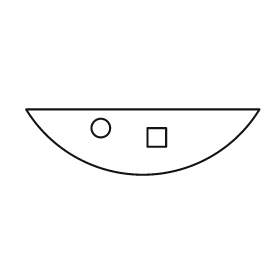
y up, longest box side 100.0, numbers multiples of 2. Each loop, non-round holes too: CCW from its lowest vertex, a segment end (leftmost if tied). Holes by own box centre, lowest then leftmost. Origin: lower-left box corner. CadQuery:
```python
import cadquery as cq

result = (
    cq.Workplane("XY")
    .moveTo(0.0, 28.0)
    .threePointArc((50.0, 0.0), (100.0, 28.0))
    .close()
    .moveTo(52.0, 12.0)
    .lineTo(60.0, 12.0)
    .lineTo(60.0, 20.0)
    .lineTo(52.0, 20.0)
    .close()
    .moveTo(32.0, 20.0)
    .circle(4.0)
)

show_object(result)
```